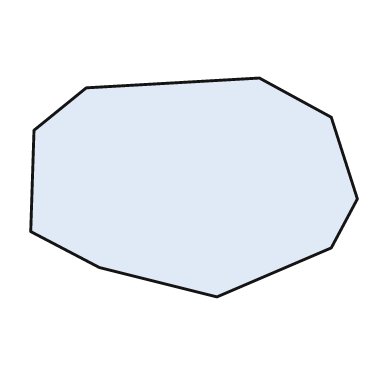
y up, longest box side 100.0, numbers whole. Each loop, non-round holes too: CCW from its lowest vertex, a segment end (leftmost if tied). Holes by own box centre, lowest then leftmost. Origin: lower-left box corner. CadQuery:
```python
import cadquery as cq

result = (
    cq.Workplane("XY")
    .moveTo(57.0, 0.0)
    .lineTo(92.0, 15.0)
    .lineTo(100.0, 30.0)
    .lineTo(92.0, 55.0)
    .lineTo(70.0, 67.0)
    .lineTo(17.0, 64.0)
    .lineTo(1.0, 51.0)
    .lineTo(0.0, 20.0)
    .lineTo(21.0, 9.0)
    .close()
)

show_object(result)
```